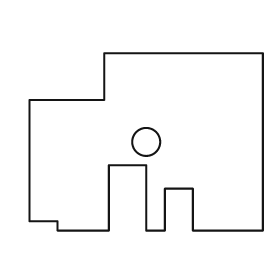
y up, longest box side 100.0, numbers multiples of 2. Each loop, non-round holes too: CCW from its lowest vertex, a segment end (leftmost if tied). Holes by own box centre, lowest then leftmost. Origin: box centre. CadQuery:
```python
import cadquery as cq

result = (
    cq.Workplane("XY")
    .moveTo(-38.0, -38.0)
    .lineTo(-16.0, -38.0)
    .lineTo(-16.0, -10.0)
    .lineTo(0.0, -10.0)
    .lineTo(0.0, -38.0)
    .lineTo(8.0, -38.0)
    .lineTo(8.0, -20.0)
    .lineTo(20.0, -20.0)
    .lineTo(20.0, -38.0)
    .lineTo(50.0, -38.0)
    .lineTo(50.0, 38.0)
    .lineTo(-18.0, 38.0)
    .lineTo(-18.0, 18.0)
    .lineTo(-50.0, 18.0)
    .lineTo(-50.0, -34.0)
    .lineTo(-38.0, -34.0)
    .close()
    .moveTo(0.0, 0.0)
    .circle(6.0)
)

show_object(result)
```